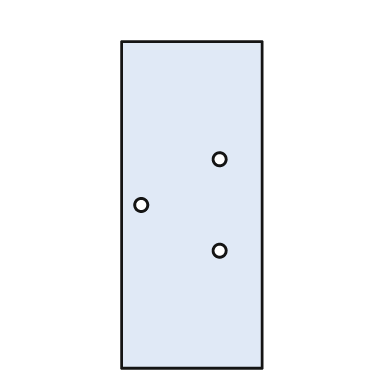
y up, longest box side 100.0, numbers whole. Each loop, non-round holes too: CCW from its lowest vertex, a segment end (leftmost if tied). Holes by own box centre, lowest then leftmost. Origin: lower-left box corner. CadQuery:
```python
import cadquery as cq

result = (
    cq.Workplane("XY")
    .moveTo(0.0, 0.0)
    .lineTo(43.0, 0.0)
    .lineTo(43.0, 100.0)
    .lineTo(0.0, 100.0)
    .close()
    .moveTo(30.0, 36.0)
    .circle(2.0)
    .moveTo(6.0, 50.0)
    .circle(2.0)
    .moveTo(30.0, 64.0)
    .circle(2.0)
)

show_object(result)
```